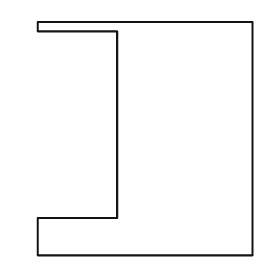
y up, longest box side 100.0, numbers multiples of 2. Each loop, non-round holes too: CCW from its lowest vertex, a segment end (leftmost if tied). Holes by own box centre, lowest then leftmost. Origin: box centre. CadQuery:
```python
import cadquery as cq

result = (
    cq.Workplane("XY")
    .moveTo(-46.0, -50.0)
    .lineTo(46.0, -50.0)
    .lineTo(46.0, 50.0)
    .lineTo(-46.0, 50.0)
    .lineTo(-46.0, 46.0)
    .lineTo(-12.0, 46.0)
    .lineTo(-12.0, -34.0)
    .lineTo(-46.0, -34.0)
    .close()
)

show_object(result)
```